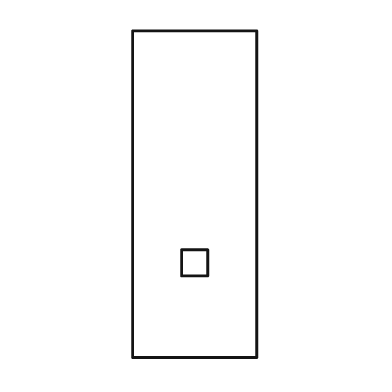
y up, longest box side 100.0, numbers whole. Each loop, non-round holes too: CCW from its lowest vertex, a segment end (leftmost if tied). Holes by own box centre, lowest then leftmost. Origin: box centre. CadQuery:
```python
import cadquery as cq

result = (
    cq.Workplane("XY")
    .moveTo(-19.0, -50.0)
    .lineTo(19.0, -50.0)
    .lineTo(19.0, 50.0)
    .lineTo(-19.0, 50.0)
    .close()
    .moveTo(-4.0, -25.0)
    .lineTo(4.0, -25.0)
    .lineTo(4.0, -17.0)
    .lineTo(-4.0, -17.0)
    .close()
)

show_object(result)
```